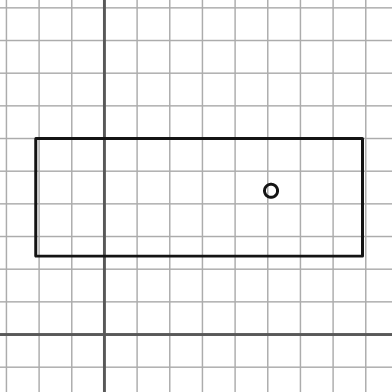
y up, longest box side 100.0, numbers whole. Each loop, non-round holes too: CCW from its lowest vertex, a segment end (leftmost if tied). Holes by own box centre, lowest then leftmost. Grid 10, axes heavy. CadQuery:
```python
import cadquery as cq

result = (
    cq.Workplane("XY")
    .moveTo(-21.0, 24.0)
    .lineTo(79.0, 24.0)
    .lineTo(79.0, 60.0)
    .lineTo(-21.0, 60.0)
    .close()
    .moveTo(51.0, 44.0)
    .circle(2.0)
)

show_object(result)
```